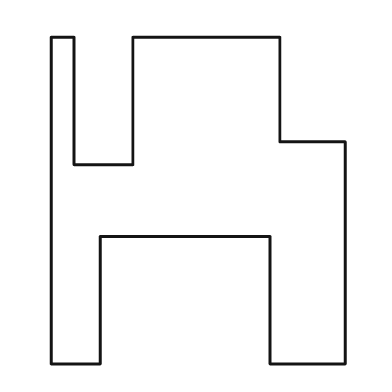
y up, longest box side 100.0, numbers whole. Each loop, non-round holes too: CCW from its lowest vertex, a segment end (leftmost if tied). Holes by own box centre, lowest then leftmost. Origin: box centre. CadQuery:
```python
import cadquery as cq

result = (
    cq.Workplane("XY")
    .moveTo(-45.0, -50.0)
    .lineTo(-30.0, -50.0)
    .lineTo(-30.0, -11.0)
    .lineTo(22.0, -11.0)
    .lineTo(22.0, -50.0)
    .lineTo(45.0, -50.0)
    .lineTo(45.0, 18.0)
    .lineTo(25.0, 18.0)
    .lineTo(25.0, 50.0)
    .lineTo(-20.0, 50.0)
    .lineTo(-20.0, 11.0)
    .lineTo(-38.0, 11.0)
    .lineTo(-38.0, 50.0)
    .lineTo(-45.0, 50.0)
    .close()
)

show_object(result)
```